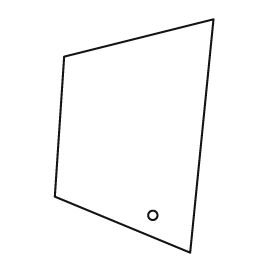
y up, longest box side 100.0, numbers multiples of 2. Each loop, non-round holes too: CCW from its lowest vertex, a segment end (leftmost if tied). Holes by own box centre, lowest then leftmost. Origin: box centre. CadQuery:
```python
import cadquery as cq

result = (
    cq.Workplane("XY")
    .moveTo(24.0, -50.0)
    .lineTo(34.0, 50.0)
    .lineTo(-30.0, 34.0)
    .lineTo(-34.0, -26.0)
    .close()
    .moveTo(8.0, -34.0)
    .circle(2.0)
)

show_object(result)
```